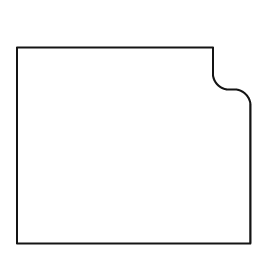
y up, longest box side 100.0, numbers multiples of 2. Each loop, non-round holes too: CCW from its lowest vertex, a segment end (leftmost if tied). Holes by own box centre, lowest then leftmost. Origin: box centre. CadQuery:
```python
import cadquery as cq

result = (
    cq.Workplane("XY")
    .moveTo(-50.0, -42.0)
    .lineTo(50.0, -42.0)
    .lineTo(50.0, 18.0)
    .threePointArc((48.0, 22.0), (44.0, 24.0))
    .lineTo(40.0, 24.0)
    .threePointArc((36.0, 26.0), (34.0, 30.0))
    .lineTo(34.0, 42.0)
    .lineTo(-50.0, 42.0)
    .close()
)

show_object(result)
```